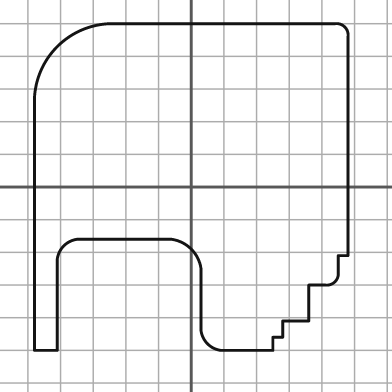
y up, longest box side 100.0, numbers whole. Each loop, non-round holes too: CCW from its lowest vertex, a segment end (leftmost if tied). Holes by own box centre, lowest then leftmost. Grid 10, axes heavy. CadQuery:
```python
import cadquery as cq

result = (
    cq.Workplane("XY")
    .moveTo(-48.0, -50.0)
    .lineTo(-41.0, -50.0)
    .lineTo(-41.0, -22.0)
    .threePointArc((-39.0, -18.0), (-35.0, -16.0))
    .lineTo(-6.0, -16.0)
    .threePointArc((0.0, -19.0), (3.0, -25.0))
    .lineTo(3.0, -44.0)
    .threePointArc((5.0, -48.0), (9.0, -50.0))
    .lineTo(25.0, -50.0)
    .lineTo(25.0, -46.0)
    .lineTo(28.0, -46.0)
    .lineTo(28.0, -41.0)
    .lineTo(36.0, -41.0)
    .lineTo(36.0, -30.0)
    .lineTo(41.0, -30.0)
    .threePointArc((44.0, -29.0), (45.0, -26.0))
    .lineTo(45.0, -21.0)
    .lineTo(48.0, -21.0)
    .lineTo(48.0, 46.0)
    .threePointArc((47.0, 49.0), (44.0, 50.0))
    .lineTo(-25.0, 50.0)
    .threePointArc((-41.0, 43.0), (-48.0, 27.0))
    .close()
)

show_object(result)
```